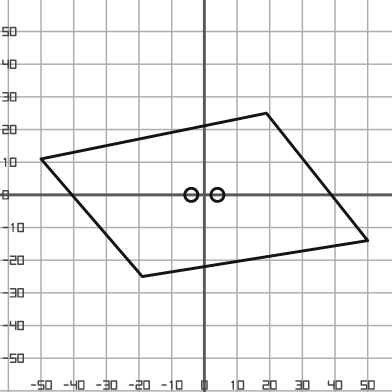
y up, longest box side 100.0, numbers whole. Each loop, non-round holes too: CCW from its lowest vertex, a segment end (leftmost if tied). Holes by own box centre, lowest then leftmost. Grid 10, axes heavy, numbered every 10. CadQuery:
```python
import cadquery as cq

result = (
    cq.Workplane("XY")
    .moveTo(-19.0, -25.0)
    .lineTo(50.0, -14.0)
    .lineTo(19.0, 25.0)
    .lineTo(-50.0, 11.0)
    .close()
    .moveTo(-4.0, 0.0)
    .circle(2.0)
    .moveTo(4.0, 0.0)
    .circle(2.0)
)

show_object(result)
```